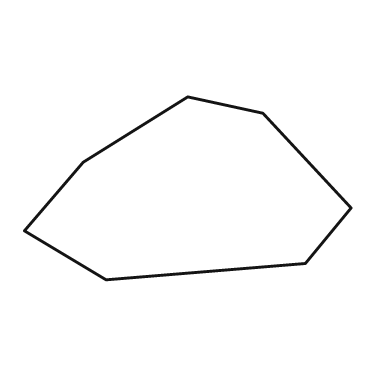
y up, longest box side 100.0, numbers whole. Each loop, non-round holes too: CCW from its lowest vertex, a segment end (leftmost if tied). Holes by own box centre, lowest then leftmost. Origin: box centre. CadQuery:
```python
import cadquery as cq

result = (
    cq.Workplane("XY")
    .moveTo(-25.0, -28.0)
    .lineTo(36.0, -23.0)
    .lineTo(50.0, -6.0)
    .lineTo(23.0, 23.0)
    .lineTo(0.0, 28.0)
    .lineTo(-32.0, 8.0)
    .lineTo(-50.0, -13.0)
    .close()
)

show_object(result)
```